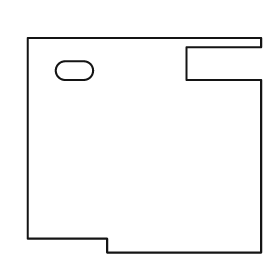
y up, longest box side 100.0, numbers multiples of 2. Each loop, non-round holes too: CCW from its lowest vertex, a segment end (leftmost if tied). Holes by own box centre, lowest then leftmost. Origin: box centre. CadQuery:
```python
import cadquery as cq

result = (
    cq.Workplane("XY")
    .moveTo(-16.0, -46.0)
    .lineTo(50.0, -46.0)
    .lineTo(50.0, 28.0)
    .lineTo(18.0, 28.0)
    .lineTo(18.0, 42.0)
    .lineTo(50.0, 42.0)
    .lineTo(50.0, 46.0)
    .lineTo(-50.0, 46.0)
    .lineTo(-50.0, -40.0)
    .lineTo(-16.0, -40.0)
    .close()
    .moveTo(-34.0, 28.0)
    .lineTo(-26.0, 28.0)
    .threePointArc((-22.0, 32.0), (-26.0, 36.0))
    .lineTo(-34.0, 36.0)
    .threePointArc((-38.0, 32.0), (-34.0, 28.0))
    .close()
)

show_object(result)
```